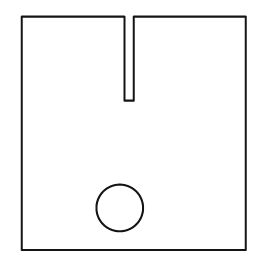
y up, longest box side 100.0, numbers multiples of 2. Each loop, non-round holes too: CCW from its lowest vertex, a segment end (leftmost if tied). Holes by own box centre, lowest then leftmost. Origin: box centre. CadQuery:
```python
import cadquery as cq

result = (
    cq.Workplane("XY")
    .moveTo(-48.0, -50.0)
    .lineTo(48.0, -50.0)
    .lineTo(48.0, 50.0)
    .lineTo(0.0, 50.0)
    .lineTo(0.0, 14.0)
    .lineTo(-4.0, 14.0)
    .lineTo(-4.0, 50.0)
    .lineTo(-48.0, 50.0)
    .close()
    .moveTo(-6.0, -32.0)
    .circle(10.0)
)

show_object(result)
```